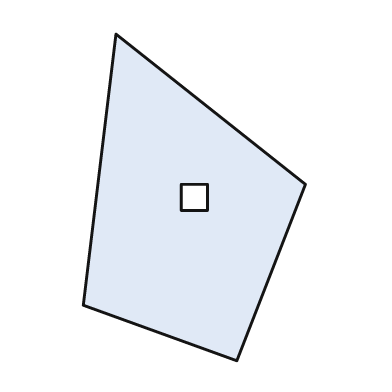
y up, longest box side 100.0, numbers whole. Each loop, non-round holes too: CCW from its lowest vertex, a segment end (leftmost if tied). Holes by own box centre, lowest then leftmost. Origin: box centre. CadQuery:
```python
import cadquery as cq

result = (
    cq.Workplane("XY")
    .moveTo(13.0, -50.0)
    .lineTo(34.0, 4.0)
    .lineTo(-24.0, 50.0)
    .lineTo(-34.0, -33.0)
    .close()
    .moveTo(-4.0, -4.0)
    .lineTo(4.0, -4.0)
    .lineTo(4.0, 4.0)
    .lineTo(-4.0, 4.0)
    .close()
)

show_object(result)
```